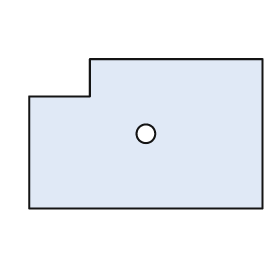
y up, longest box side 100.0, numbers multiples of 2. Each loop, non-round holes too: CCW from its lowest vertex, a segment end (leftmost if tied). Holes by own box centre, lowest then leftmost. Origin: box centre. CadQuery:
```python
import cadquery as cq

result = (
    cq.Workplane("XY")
    .moveTo(-50.0, -32.0)
    .lineTo(50.0, -32.0)
    .lineTo(50.0, 32.0)
    .lineTo(-24.0, 32.0)
    .lineTo(-24.0, 16.0)
    .lineTo(-50.0, 16.0)
    .close()
    .moveTo(0.0, 0.0)
    .circle(4.0)
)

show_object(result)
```